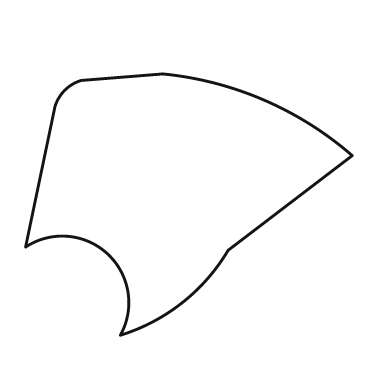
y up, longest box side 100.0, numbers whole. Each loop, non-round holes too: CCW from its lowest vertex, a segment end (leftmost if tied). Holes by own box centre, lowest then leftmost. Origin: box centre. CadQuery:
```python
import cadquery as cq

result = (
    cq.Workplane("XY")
    .moveTo(-21.0, -40.0)
    .threePointArc((-2.0, -30.0), (12.0, -14.0))
    .lineTo(50.0, 15.0)
    .threePointArc((23.0, 32.0), (-8.0, 40.0))
    .lineTo(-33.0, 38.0)
    .threePointArc((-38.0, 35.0), (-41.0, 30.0))
    .lineTo(-50.0, -13.0)
    .threePointArc((-25.0, -15.0), (-21.0, -40.0))
    .close()
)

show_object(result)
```